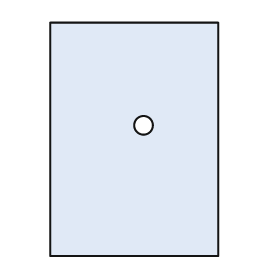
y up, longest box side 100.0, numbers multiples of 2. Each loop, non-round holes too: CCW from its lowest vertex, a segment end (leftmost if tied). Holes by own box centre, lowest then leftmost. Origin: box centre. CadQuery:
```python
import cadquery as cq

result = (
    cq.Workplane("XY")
    .moveTo(-36.0, -50.0)
    .lineTo(36.0, -50.0)
    .lineTo(36.0, 50.0)
    .lineTo(-36.0, 50.0)
    .close()
    .moveTo(4.0, 6.0)
    .circle(4.0)
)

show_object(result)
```